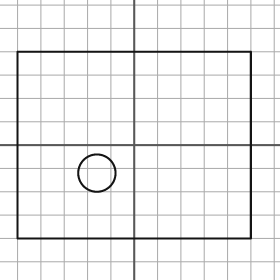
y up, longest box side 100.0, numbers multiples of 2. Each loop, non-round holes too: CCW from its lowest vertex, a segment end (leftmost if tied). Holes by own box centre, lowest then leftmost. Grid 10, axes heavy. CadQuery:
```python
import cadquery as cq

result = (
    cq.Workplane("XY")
    .moveTo(-50.0, -40.0)
    .lineTo(50.0, -40.0)
    .lineTo(50.0, 40.0)
    .lineTo(-50.0, 40.0)
    .close()
    .moveTo(-16.0, -12.0)
    .circle(8.0)
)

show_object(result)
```